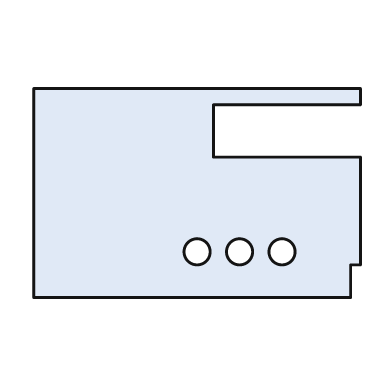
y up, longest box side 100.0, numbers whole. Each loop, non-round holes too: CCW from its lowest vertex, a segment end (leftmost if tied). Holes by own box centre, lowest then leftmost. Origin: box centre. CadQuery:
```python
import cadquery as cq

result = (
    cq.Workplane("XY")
    .moveTo(-50.0, -32.0)
    .lineTo(47.0, -32.0)
    .lineTo(47.0, -22.0)
    .lineTo(50.0, -22.0)
    .lineTo(50.0, 11.0)
    .lineTo(5.0, 11.0)
    .lineTo(5.0, 27.0)
    .lineTo(50.0, 27.0)
    .lineTo(50.0, 32.0)
    .lineTo(-50.0, 32.0)
    .close()
    .moveTo(0.0, -18.0)
    .circle(4.0)
    .moveTo(13.0, -18.0)
    .circle(4.0)
    .moveTo(26.0, -18.0)
    .circle(4.0)
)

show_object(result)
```